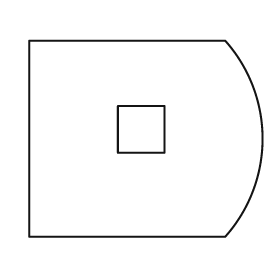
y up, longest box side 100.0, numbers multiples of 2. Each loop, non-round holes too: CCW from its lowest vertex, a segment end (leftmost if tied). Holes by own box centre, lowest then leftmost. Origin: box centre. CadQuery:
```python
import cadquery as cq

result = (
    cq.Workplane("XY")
    .moveTo(-50.0, -42.0)
    .lineTo(34.0, -42.0)
    .threePointArc((50.0, 0.0), (34.0, 42.0))
    .lineTo(-50.0, 42.0)
    .close()
    .moveTo(-12.0, -6.0)
    .lineTo(8.0, -6.0)
    .lineTo(8.0, 14.0)
    .lineTo(-12.0, 14.0)
    .close()
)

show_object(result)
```